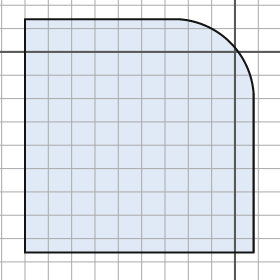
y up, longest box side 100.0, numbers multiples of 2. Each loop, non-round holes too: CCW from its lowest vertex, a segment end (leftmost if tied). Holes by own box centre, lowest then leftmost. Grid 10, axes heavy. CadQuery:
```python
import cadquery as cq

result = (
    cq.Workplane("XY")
    .moveTo(-90.0, -86.0)
    .lineTo(8.0, -86.0)
    .lineTo(8.0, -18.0)
    .threePointArc((-2.0, 4.0), (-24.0, 14.0))
    .lineTo(-90.0, 14.0)
    .close()
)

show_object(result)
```